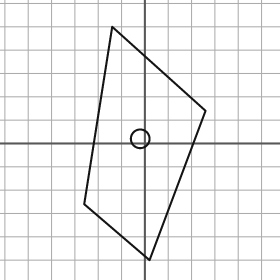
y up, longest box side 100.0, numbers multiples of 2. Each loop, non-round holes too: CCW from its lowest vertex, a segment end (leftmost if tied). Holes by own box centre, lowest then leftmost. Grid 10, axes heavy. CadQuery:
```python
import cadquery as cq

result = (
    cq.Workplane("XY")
    .moveTo(2.0, -50.0)
    .lineTo(26.0, 14.0)
    .lineTo(-14.0, 50.0)
    .lineTo(-26.0, -26.0)
    .close()
    .moveTo(-2.0, 2.0)
    .circle(4.0)
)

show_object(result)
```